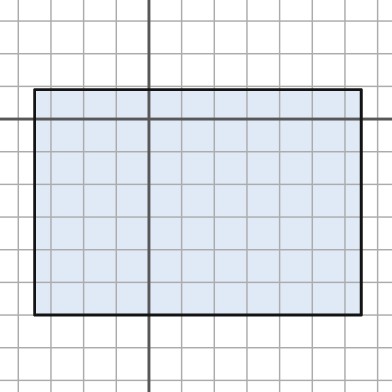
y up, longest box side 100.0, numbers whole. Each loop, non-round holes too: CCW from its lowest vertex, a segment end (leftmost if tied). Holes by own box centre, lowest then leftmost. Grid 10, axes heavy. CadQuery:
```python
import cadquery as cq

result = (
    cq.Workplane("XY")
    .moveTo(-35.0, -60.0)
    .lineTo(65.0, -60.0)
    .lineTo(65.0, 9.0)
    .lineTo(-35.0, 9.0)
    .close()
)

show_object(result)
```